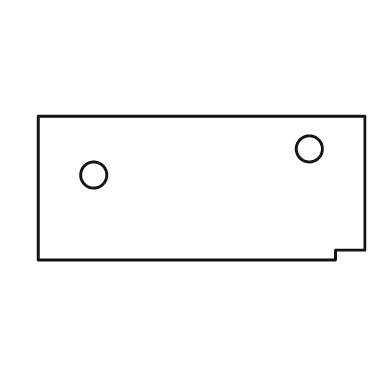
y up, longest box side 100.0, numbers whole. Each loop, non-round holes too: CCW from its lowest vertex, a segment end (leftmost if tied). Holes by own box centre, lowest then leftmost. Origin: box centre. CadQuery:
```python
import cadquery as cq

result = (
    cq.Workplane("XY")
    .moveTo(-50.0, -22.0)
    .lineTo(41.0, -22.0)
    .lineTo(41.0, -19.0)
    .lineTo(50.0, -19.0)
    .lineTo(50.0, 22.0)
    .lineTo(-50.0, 22.0)
    .close()
    .moveTo(-33.0, 4.0)
    .circle(4.0)
    .moveTo(33.0, 12.0)
    .circle(4.0)
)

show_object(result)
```